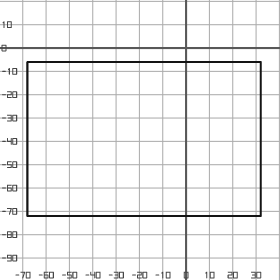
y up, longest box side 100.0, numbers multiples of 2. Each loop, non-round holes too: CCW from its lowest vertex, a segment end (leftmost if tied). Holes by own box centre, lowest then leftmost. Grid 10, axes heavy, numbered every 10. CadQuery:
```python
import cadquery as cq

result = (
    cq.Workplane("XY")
    .moveTo(-68.0, -72.0)
    .lineTo(32.0, -72.0)
    .lineTo(32.0, -6.0)
    .lineTo(-68.0, -6.0)
    .close()
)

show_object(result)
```